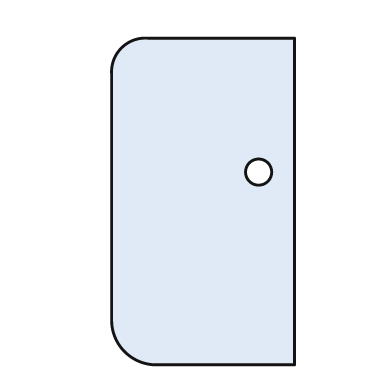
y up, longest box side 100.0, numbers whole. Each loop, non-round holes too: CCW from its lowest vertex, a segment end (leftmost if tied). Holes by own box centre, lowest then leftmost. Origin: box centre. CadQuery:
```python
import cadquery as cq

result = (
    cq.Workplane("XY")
    .moveTo(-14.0, -50.0)
    .lineTo(28.0, -50.0)
    .lineTo(28.0, 50.0)
    .lineTo(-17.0, 50.0)
    .threePointArc((-25.0, 47.0), (-28.0, 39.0))
    .lineTo(-28.0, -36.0)
    .threePointArc((-24.0, -46.0), (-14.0, -50.0))
    .close()
    .moveTo(17.0, 9.0)
    .circle(4.0)
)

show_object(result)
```